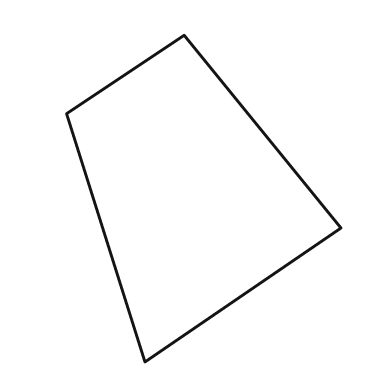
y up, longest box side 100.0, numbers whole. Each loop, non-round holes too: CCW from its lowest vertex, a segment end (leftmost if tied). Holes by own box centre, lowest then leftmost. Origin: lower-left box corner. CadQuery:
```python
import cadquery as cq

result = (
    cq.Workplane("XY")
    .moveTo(24.0, 0.0)
    .lineTo(84.0, 41.0)
    .lineTo(36.0, 100.0)
    .lineTo(0.0, 76.0)
    .close()
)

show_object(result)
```